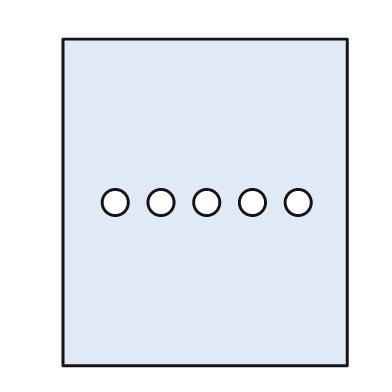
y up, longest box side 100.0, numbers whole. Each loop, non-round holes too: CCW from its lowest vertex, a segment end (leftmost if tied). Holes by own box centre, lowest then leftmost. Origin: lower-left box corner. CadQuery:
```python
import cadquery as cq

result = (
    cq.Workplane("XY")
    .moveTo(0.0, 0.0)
    .lineTo(87.0, 0.0)
    .lineTo(87.0, 100.0)
    .lineTo(0.0, 100.0)
    .close()
    .moveTo(16.0, 50.0)
    .circle(4.0)
    .moveTo(30.0, 50.0)
    .circle(4.0)
    .moveTo(44.0, 50.0)
    .circle(4.0)
    .moveTo(58.0, 50.0)
    .circle(4.0)
    .moveTo(72.0, 50.0)
    .circle(4.0)
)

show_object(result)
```